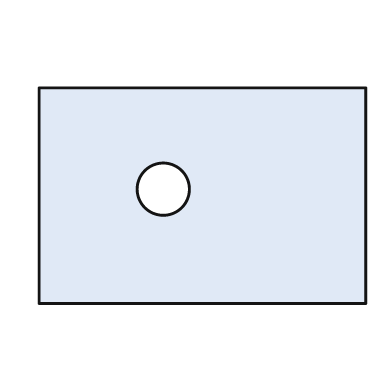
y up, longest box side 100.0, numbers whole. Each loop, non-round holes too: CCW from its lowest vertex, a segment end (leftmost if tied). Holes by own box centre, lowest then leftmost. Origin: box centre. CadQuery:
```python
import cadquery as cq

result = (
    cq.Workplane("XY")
    .moveTo(-50.0, -33.0)
    .lineTo(50.0, -33.0)
    .lineTo(50.0, 33.0)
    .lineTo(-50.0, 33.0)
    .close()
    .moveTo(-12.0, 2.0)
    .circle(8.0)
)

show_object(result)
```